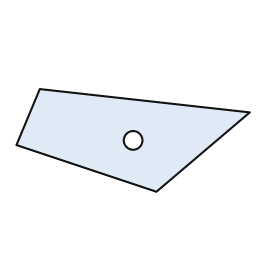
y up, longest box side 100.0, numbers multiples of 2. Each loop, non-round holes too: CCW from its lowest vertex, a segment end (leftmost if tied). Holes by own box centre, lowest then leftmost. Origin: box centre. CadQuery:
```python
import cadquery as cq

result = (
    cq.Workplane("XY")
    .moveTo(10.0, -22.0)
    .lineTo(50.0, 12.0)
    .lineTo(-40.0, 22.0)
    .lineTo(-50.0, -2.0)
    .close()
    .moveTo(0.0, 0.0)
    .circle(4.0)
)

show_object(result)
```